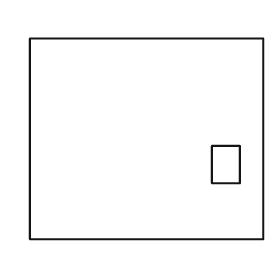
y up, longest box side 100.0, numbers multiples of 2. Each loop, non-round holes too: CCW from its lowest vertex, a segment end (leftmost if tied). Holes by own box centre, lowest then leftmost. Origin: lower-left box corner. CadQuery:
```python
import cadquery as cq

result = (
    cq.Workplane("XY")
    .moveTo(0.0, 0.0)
    .lineTo(100.0, 0.0)
    .lineTo(100.0, 86.0)
    .lineTo(0.0, 86.0)
    .close()
    .moveTo(78.0, 24.0)
    .lineTo(90.0, 24.0)
    .lineTo(90.0, 40.0)
    .lineTo(78.0, 40.0)
    .close()
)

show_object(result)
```